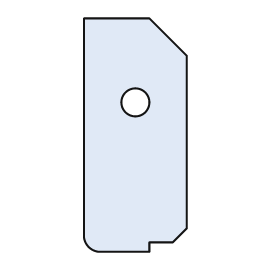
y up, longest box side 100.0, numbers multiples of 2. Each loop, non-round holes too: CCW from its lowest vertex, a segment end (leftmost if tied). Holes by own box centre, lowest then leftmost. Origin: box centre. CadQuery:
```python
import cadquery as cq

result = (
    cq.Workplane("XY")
    .moveTo(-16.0, -50.0)
    .lineTo(6.0, -50.0)
    .lineTo(6.0, -46.0)
    .lineTo(16.0, -46.0)
    .lineTo(22.0, -40.0)
    .lineTo(22.0, 34.0)
    .lineTo(6.0, 50.0)
    .lineTo(-22.0, 50.0)
    .lineTo(-22.0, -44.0)
    .threePointArc((-20.0, -48.0), (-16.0, -50.0))
    .close()
    .moveTo(0.0, 14.0)
    .circle(6.0)
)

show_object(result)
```